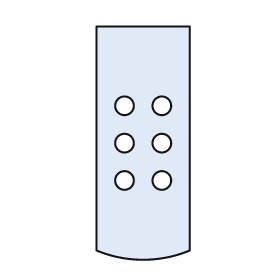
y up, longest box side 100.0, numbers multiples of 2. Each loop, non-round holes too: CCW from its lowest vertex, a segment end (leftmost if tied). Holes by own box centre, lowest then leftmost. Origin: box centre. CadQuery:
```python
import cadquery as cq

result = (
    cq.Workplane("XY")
    .moveTo(-20.0, -46.0)
    .threePointArc((0.0, -50.0), (20.0, -46.0))
    .lineTo(20.0, 50.0)
    .lineTo(-20.0, 50.0)
    .close()
    .moveTo(-8.0, -16.0)
    .circle(4.0)
    .moveTo(8.0, -16.0)
    .circle(4.0)
    .moveTo(-8.0, 0.0)
    .circle(4.0)
    .moveTo(8.0, 0.0)
    .circle(4.0)
    .moveTo(-8.0, 16.0)
    .circle(4.0)
    .moveTo(8.0, 16.0)
    .circle(4.0)
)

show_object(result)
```